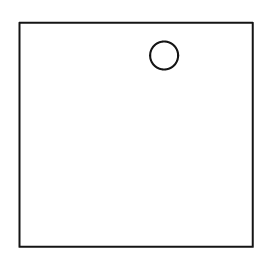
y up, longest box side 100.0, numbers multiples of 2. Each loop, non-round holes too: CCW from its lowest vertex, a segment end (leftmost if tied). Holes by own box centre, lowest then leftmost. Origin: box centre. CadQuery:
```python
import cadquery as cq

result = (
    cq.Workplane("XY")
    .moveTo(-50.0, -48.0)
    .lineTo(50.0, -48.0)
    .lineTo(50.0, 48.0)
    .lineTo(-50.0, 48.0)
    .close()
    .moveTo(12.0, 34.0)
    .circle(6.0)
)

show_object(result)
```